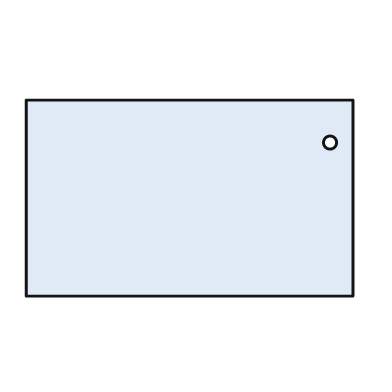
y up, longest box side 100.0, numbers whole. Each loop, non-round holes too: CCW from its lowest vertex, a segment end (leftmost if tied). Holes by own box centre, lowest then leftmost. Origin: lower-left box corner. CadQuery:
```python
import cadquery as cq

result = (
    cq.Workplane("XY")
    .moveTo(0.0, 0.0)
    .lineTo(100.0, 0.0)
    .lineTo(100.0, 60.0)
    .lineTo(0.0, 60.0)
    .close()
    .moveTo(93.0, 47.0)
    .circle(2.0)
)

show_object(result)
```